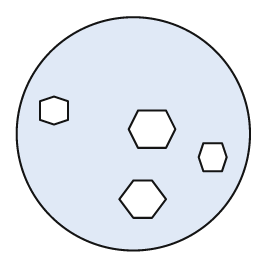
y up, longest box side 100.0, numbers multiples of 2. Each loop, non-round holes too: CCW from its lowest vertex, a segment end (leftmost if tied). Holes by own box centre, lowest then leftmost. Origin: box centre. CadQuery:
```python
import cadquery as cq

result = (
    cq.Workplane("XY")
    .moveTo(0.0, 0.0)
    .circle(50.0)
    .moveTo(0.0, -36.0)
    .lineTo(8.0, -36.0)
    .lineTo(14.0, -28.0)
    .lineTo(8.0, -20.0)
    .lineTo(0.0, -20.0)
    .lineTo(-6.0, -28.0)
    .close()
    .moveTo(30.0, -16.0)
    .lineTo(38.0, -16.0)
    .lineTo(40.0, -10.0)
    .lineTo(38.0, -4.0)
    .lineTo(30.0, -4.0)
    .lineTo(28.0, -10.0)
    .close()
    .moveTo(2.0, -6.0)
    .lineTo(14.0, -6.0)
    .lineTo(18.0, 2.0)
    .lineTo(14.0, 10.0)
    .lineTo(2.0, 10.0)
    .lineTo(-2.0, 2.0)
    .close()
    .moveTo(-34.0, 4.0)
    .lineTo(-28.0, 6.0)
    .lineTo(-28.0, 14.0)
    .lineTo(-34.0, 16.0)
    .lineTo(-40.0, 14.0)
    .lineTo(-40.0, 6.0)
    .close()
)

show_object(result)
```